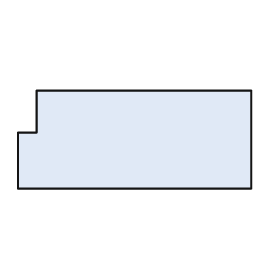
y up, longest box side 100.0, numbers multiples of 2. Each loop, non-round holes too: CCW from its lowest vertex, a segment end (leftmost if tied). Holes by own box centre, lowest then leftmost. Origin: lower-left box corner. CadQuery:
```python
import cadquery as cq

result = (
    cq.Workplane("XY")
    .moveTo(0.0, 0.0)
    .lineTo(100.0, 0.0)
    .lineTo(100.0, 42.0)
    .lineTo(8.0, 42.0)
    .lineTo(8.0, 24.0)
    .lineTo(0.0, 24.0)
    .close()
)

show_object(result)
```